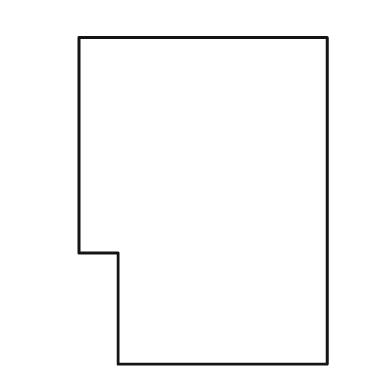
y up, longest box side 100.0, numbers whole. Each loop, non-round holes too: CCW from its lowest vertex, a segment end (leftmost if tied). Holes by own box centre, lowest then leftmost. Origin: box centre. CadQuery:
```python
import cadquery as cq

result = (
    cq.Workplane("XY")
    .moveTo(-26.0, -50.0)
    .lineTo(38.0, -50.0)
    .lineTo(38.0, 50.0)
    .lineTo(-38.0, 50.0)
    .lineTo(-38.0, -16.0)
    .lineTo(-26.0, -16.0)
    .close()
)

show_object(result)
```